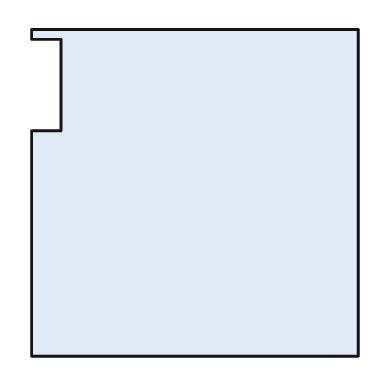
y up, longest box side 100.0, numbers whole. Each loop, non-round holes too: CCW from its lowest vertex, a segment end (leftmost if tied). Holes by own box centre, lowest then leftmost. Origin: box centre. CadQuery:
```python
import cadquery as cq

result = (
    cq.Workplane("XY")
    .moveTo(-50.0, -50.0)
    .lineTo(50.0, -50.0)
    .lineTo(50.0, 50.0)
    .lineTo(-50.0, 50.0)
    .lineTo(-50.0, 47.0)
    .lineTo(-41.0, 47.0)
    .lineTo(-41.0, 19.0)
    .lineTo(-50.0, 19.0)
    .close()
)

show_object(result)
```